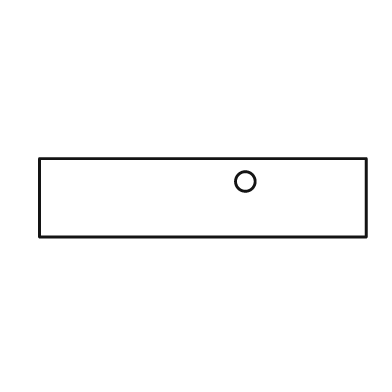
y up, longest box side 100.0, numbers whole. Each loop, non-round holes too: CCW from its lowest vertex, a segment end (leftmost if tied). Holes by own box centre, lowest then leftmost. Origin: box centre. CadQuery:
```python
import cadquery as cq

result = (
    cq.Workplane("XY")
    .moveTo(-50.0, -12.0)
    .lineTo(50.0, -12.0)
    .lineTo(50.0, 12.0)
    .lineTo(-50.0, 12.0)
    .close()
    .moveTo(13.0, 5.0)
    .circle(3.0)
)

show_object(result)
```